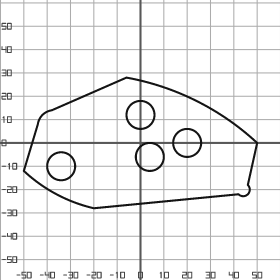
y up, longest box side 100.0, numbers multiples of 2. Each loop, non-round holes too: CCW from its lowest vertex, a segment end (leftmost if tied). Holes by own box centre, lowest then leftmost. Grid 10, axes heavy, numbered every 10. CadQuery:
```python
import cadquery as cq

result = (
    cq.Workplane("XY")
    .moveTo(-20.0, -28.0)
    .lineTo(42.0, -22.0)
    .threePointArc((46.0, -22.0), (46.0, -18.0))
    .lineTo(50.0, 0.0)
    .threePointArc((24.0, 18.0), (-6.0, 28.0))
    .lineTo(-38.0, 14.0)
    .threePointArc((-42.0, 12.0), (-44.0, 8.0))
    .lineTo(-50.0, -12.0)
    .threePointArc((-36.0, -22.0), (-20.0, -28.0))
    .close()
    .moveTo(-34.0, -10.0)
    .circle(6.0)
    .moveTo(4.0, -6.0)
    .circle(6.0)
    .moveTo(20.0, 0.0)
    .circle(6.0)
    .moveTo(0.0, 12.0)
    .circle(6.0)
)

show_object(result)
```